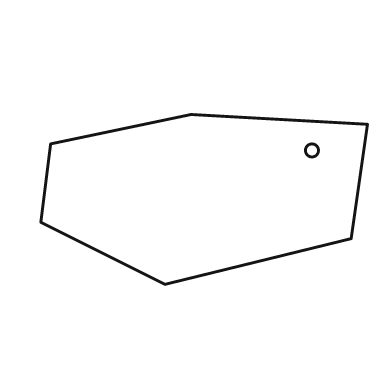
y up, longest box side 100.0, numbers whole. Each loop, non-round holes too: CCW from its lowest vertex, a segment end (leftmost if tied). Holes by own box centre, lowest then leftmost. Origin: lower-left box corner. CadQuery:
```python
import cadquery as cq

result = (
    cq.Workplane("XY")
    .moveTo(38.0, 0.0)
    .lineTo(95.0, 14.0)
    .lineTo(100.0, 49.0)
    .lineTo(46.0, 52.0)
    .lineTo(3.0, 43.0)
    .lineTo(0.0, 19.0)
    .close()
    .moveTo(83.0, 41.0)
    .circle(2.0)
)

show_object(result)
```